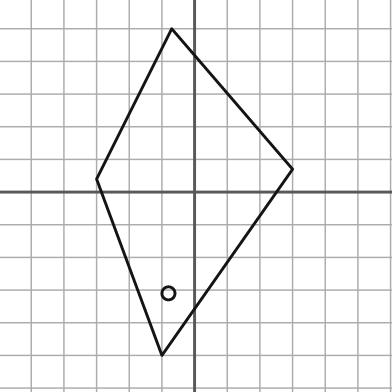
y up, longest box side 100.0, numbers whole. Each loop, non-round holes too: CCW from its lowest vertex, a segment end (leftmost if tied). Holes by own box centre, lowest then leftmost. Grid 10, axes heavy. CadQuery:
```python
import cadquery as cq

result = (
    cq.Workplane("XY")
    .moveTo(-10.0, -50.0)
    .lineTo(30.0, 7.0)
    .lineTo(-7.0, 50.0)
    .lineTo(-30.0, 4.0)
    .close()
    .moveTo(-8.0, -31.0)
    .circle(2.0)
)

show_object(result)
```